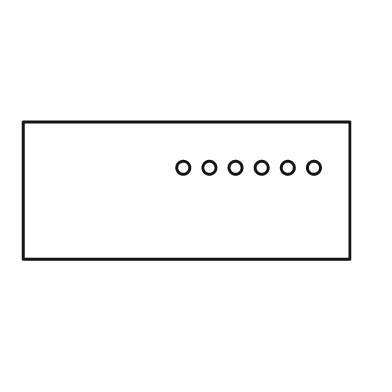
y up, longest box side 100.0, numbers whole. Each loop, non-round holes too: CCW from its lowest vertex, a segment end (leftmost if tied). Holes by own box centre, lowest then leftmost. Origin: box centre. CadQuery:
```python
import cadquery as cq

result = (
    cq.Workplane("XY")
    .moveTo(-50.0, -21.0)
    .lineTo(50.0, -21.0)
    .lineTo(50.0, 21.0)
    .lineTo(-50.0, 21.0)
    .close()
    .moveTo(-1.0, 7.0)
    .circle(2.0)
    .moveTo(7.0, 7.0)
    .circle(2.0)
    .moveTo(15.0, 7.0)
    .circle(2.0)
    .moveTo(23.0, 7.0)
    .circle(2.0)
    .moveTo(31.0, 7.0)
    .circle(2.0)
    .moveTo(39.0, 7.0)
    .circle(2.0)
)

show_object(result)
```